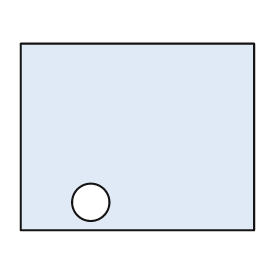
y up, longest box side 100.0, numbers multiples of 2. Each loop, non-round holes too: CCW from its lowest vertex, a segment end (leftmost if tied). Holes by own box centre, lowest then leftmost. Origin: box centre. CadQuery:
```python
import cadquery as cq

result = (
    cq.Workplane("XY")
    .moveTo(-50.0, -40.0)
    .lineTo(50.0, -40.0)
    .lineTo(50.0, 40.0)
    .lineTo(-50.0, 40.0)
    .close()
    .moveTo(-20.0, -28.0)
    .circle(8.0)
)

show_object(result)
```